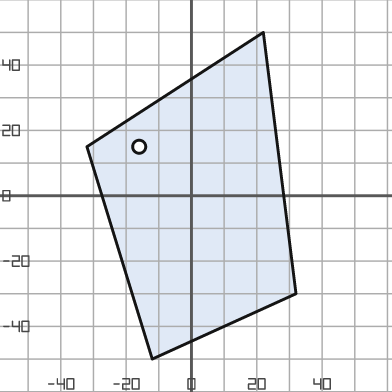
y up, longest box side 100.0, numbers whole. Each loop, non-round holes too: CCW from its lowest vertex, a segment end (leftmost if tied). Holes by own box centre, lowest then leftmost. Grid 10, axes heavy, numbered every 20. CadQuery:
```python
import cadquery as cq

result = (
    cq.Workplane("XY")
    .moveTo(-12.0, -50.0)
    .lineTo(32.0, -30.0)
    .lineTo(22.0, 50.0)
    .lineTo(-32.0, 15.0)
    .close()
    .moveTo(-16.0, 15.0)
    .circle(2.0)
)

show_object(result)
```